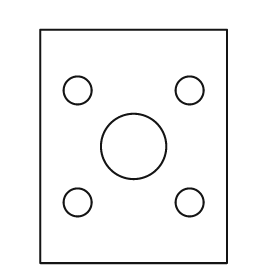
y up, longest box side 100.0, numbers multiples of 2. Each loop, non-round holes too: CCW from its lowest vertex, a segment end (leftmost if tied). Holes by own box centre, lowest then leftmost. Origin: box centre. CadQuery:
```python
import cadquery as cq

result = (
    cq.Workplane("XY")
    .moveTo(-40.0, -50.0)
    .lineTo(40.0, -50.0)
    .lineTo(40.0, 50.0)
    .lineTo(-40.0, 50.0)
    .close()
    .moveTo(-24.0, -24.0)
    .circle(6.0)
    .moveTo(24.0, -24.0)
    .circle(6.0)
    .moveTo(0.0, 0.0)
    .circle(14.0)
    .moveTo(-24.0, 24.0)
    .circle(6.0)
    .moveTo(24.0, 24.0)
    .circle(6.0)
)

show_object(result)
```